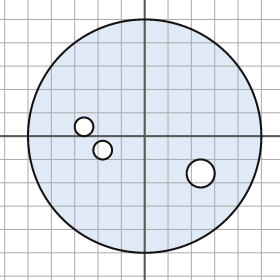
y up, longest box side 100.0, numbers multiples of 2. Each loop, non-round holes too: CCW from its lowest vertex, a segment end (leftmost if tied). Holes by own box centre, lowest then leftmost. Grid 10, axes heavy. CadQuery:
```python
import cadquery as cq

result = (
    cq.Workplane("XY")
    .moveTo(0.0, 0.0)
    .circle(50.0)
    .moveTo(24.0, -16.0)
    .circle(6.0)
    .moveTo(-18.0, -6.0)
    .circle(4.0)
    .moveTo(-26.0, 4.0)
    .circle(4.0)
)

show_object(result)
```